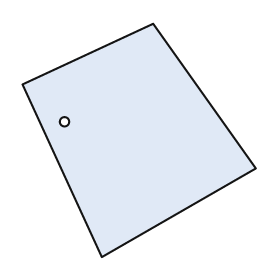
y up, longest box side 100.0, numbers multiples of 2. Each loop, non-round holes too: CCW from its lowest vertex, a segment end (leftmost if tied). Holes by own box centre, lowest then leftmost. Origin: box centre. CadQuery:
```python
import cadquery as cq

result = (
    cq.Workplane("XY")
    .moveTo(-16.0, -50.0)
    .lineTo(50.0, -12.0)
    .lineTo(6.0, 50.0)
    .lineTo(-50.0, 24.0)
    .close()
    .moveTo(-32.0, 8.0)
    .circle(2.0)
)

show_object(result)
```